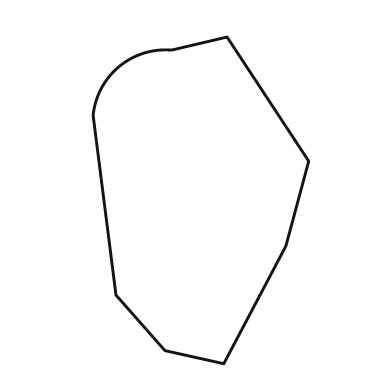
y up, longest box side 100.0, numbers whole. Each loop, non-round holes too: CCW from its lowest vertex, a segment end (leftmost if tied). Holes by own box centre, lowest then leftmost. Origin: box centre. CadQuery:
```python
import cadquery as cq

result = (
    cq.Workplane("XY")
    .moveTo(7.0, -50.0)
    .lineTo(26.0, -14.0)
    .lineTo(33.0, 12.0)
    .lineTo(8.0, 50.0)
    .lineTo(-9.0, 46.0)
    .threePointArc((-25.0, 41.0), (-33.0, 26.0))
    .lineTo(-26.0, -29.0)
    .lineTo(-11.0, -46.0)
    .close()
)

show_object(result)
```